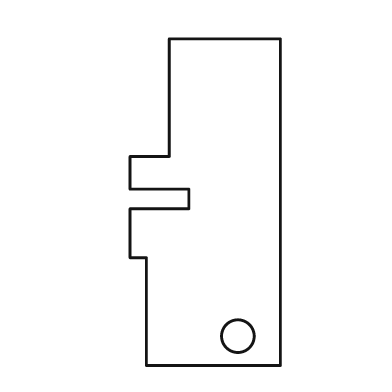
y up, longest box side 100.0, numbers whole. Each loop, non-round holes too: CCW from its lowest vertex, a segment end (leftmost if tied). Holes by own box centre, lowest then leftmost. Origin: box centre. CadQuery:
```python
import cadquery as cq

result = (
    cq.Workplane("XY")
    .moveTo(-18.0, -50.0)
    .lineTo(23.0, -50.0)
    .lineTo(23.0, 50.0)
    .lineTo(-11.0, 50.0)
    .lineTo(-11.0, 14.0)
    .lineTo(-23.0, 14.0)
    .lineTo(-23.0, 4.0)
    .lineTo(-5.0, 4.0)
    .lineTo(-5.0, -2.0)
    .lineTo(-23.0, -2.0)
    .lineTo(-23.0, -17.0)
    .lineTo(-18.0, -17.0)
    .close()
    .moveTo(10.0, -41.0)
    .circle(5.0)
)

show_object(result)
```